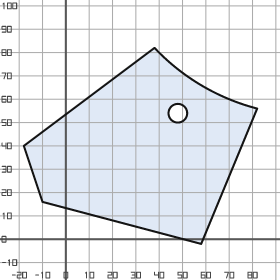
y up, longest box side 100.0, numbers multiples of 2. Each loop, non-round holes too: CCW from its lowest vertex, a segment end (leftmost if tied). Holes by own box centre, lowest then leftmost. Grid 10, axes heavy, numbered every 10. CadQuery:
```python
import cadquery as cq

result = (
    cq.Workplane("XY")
    .moveTo(58.0, -2.0)
    .lineTo(82.0, 56.0)
    .threePointArc((58.0, 66.0), (38.0, 82.0))
    .lineTo(-18.0, 40.0)
    .lineTo(-10.0, 16.0)
    .close()
    .moveTo(48.0, 54.0)
    .circle(4.0)
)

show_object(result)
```